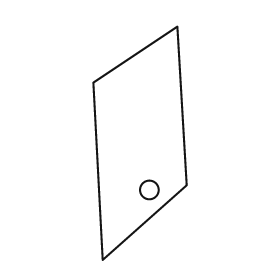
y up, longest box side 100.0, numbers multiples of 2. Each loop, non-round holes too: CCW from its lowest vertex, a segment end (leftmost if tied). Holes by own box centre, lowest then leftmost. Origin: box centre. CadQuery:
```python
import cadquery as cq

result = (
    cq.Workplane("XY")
    .moveTo(-16.0, -50.0)
    .lineTo(20.0, -18.0)
    .lineTo(16.0, 50.0)
    .lineTo(-20.0, 26.0)
    .close()
    .moveTo(4.0, -20.0)
    .circle(4.0)
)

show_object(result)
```